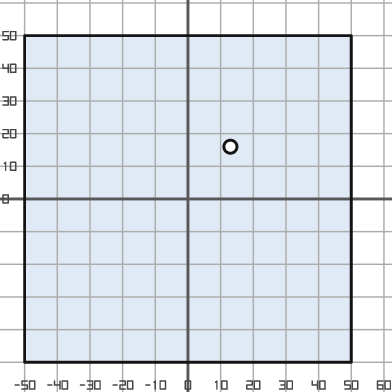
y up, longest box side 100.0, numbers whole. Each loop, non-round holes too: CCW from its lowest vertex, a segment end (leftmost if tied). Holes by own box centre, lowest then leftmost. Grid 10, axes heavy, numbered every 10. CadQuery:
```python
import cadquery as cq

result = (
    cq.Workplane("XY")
    .moveTo(-50.0, -50.0)
    .lineTo(50.0, -50.0)
    .lineTo(50.0, 50.0)
    .lineTo(-50.0, 50.0)
    .close()
    .moveTo(13.0, 16.0)
    .circle(2.0)
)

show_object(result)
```